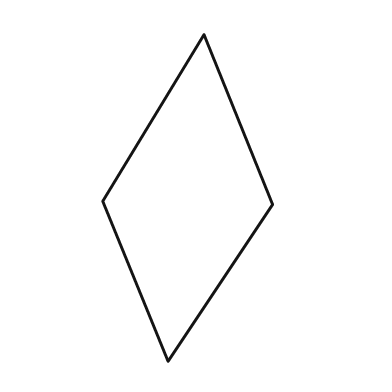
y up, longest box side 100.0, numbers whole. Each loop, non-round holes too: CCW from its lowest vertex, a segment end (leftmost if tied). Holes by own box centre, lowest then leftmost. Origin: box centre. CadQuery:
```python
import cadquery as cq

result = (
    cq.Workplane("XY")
    .moveTo(-6.0, -50.0)
    .lineTo(26.0, -2.0)
    .lineTo(5.0, 50.0)
    .lineTo(-26.0, -1.0)
    .close()
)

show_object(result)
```